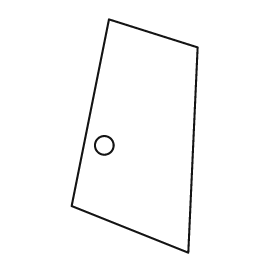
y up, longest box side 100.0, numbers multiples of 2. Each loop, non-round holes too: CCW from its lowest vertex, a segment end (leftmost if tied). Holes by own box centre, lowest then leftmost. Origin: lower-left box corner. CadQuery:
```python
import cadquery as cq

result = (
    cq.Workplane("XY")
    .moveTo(50.0, 0.0)
    .lineTo(54.0, 88.0)
    .lineTo(16.0, 100.0)
    .lineTo(0.0, 20.0)
    .close()
    .moveTo(14.0, 46.0)
    .circle(4.0)
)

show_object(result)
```